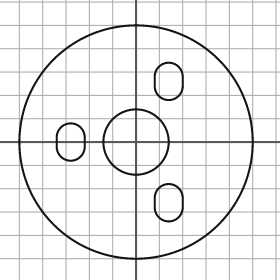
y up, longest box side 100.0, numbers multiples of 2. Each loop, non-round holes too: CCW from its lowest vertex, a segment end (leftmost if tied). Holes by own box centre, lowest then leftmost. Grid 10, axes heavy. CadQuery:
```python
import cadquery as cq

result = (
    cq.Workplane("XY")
    .moveTo(0.0, 0.0)
    .circle(50.0)
    .moveTo(8.0, -28.0)
    .threePointArc((14.0, -34.0), (20.0, -28.0))
    .lineTo(20.0, -24.0)
    .threePointArc((14.0, -18.0), (8.0, -24.0))
    .close()
    .moveTo(-34.0, -2.0)
    .threePointArc((-28.0, -8.0), (-22.0, -2.0))
    .lineTo(-22.0, 2.0)
    .threePointArc((-28.0, 8.0), (-34.0, 2.0))
    .close()
    .moveTo(0.0, 0.0)
    .circle(14.0)
    .moveTo(8.0, 24.0)
    .threePointArc((14.0, 18.0), (20.0, 24.0))
    .lineTo(20.0, 28.0)
    .threePointArc((14.0, 34.0), (8.0, 28.0))
    .close()
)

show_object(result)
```